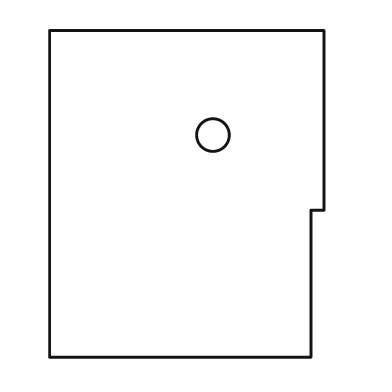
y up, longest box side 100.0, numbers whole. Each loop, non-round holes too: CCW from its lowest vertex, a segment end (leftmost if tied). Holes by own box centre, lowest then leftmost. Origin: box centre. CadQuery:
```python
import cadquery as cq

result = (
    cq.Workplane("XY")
    .moveTo(-42.0, -50.0)
    .lineTo(38.0, -50.0)
    .lineTo(38.0, -5.0)
    .lineTo(42.0, -5.0)
    .lineTo(42.0, 50.0)
    .lineTo(-42.0, 50.0)
    .close()
    .moveTo(8.0, 18.0)
    .circle(5.0)
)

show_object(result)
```